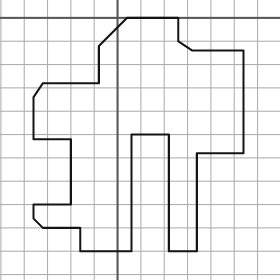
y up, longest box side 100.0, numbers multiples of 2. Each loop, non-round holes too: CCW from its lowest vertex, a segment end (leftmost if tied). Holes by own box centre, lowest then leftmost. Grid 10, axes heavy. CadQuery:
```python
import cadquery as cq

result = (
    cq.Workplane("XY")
    .moveTo(-16.0, -100.0)
    .lineTo(6.0, -100.0)
    .lineTo(6.0, -50.0)
    .lineTo(22.0, -50.0)
    .lineTo(22.0, -100.0)
    .lineTo(34.0, -100.0)
    .lineTo(34.0, -58.0)
    .lineTo(54.0, -58.0)
    .lineTo(54.0, -14.0)
    .lineTo(32.0, -14.0)
    .lineTo(26.0, -10.0)
    .lineTo(26.0, 0.0)
    .lineTo(4.0, 0.0)
    .lineTo(-8.0, -12.0)
    .lineTo(-8.0, -28.0)
    .lineTo(-32.0, -28.0)
    .lineTo(-36.0, -34.0)
    .lineTo(-36.0, -52.0)
    .lineTo(-20.0, -52.0)
    .lineTo(-20.0, -80.0)
    .lineTo(-36.0, -80.0)
    .lineTo(-36.0, -86.0)
    .lineTo(-32.0, -90.0)
    .lineTo(-16.0, -90.0)
    .close()
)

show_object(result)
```